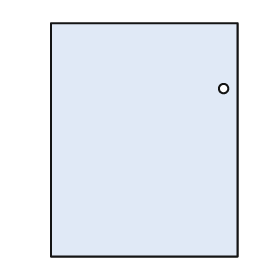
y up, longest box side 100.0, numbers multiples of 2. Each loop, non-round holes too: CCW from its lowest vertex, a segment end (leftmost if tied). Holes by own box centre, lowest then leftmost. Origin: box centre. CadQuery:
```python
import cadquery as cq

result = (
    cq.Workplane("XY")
    .moveTo(-40.0, -50.0)
    .lineTo(40.0, -50.0)
    .lineTo(40.0, 50.0)
    .lineTo(-40.0, 50.0)
    .close()
    .moveTo(34.0, 22.0)
    .circle(2.0)
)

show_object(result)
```